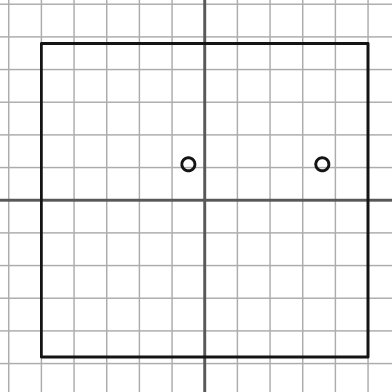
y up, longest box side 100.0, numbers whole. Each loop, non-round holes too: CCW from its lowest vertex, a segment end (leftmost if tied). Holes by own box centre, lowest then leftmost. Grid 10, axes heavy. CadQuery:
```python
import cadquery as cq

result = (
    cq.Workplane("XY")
    .moveTo(-50.0, -48.0)
    .lineTo(50.0, -48.0)
    .lineTo(50.0, 48.0)
    .lineTo(-50.0, 48.0)
    .close()
    .moveTo(-5.0, 11.0)
    .circle(2.0)
    .moveTo(36.0, 11.0)
    .circle(2.0)
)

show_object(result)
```